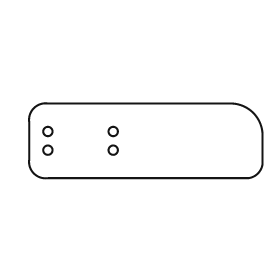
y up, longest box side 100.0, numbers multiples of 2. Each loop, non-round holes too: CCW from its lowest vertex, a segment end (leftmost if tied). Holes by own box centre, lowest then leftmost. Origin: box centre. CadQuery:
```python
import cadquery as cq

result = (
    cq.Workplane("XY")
    .moveTo(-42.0, -16.0)
    .lineTo(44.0, -16.0)
    .threePointArc((48.0, -14.0), (50.0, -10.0))
    .lineTo(50.0, 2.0)
    .threePointArc((46.0, 12.0), (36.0, 16.0))
    .lineTo(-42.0, 16.0)
    .threePointArc((-48.0, 14.0), (-50.0, 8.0))
    .lineTo(-50.0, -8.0)
    .threePointArc((-48.0, -14.0), (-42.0, -16.0))
    .close()
    .moveTo(-42.0, -4.0)
    .circle(2.0)
    .moveTo(-14.0, -4.0)
    .circle(2.0)
    .moveTo(-42.0, 4.0)
    .circle(2.0)
    .moveTo(-14.0, 4.0)
    .circle(2.0)
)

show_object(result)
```